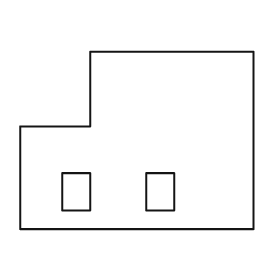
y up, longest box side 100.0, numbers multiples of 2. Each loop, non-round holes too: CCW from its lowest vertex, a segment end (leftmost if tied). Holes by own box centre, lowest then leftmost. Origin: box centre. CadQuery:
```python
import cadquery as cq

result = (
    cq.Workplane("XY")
    .moveTo(-50.0, -38.0)
    .lineTo(50.0, -38.0)
    .lineTo(50.0, 38.0)
    .lineTo(-20.0, 38.0)
    .lineTo(-20.0, 6.0)
    .lineTo(-50.0, 6.0)
    .close()
    .moveTo(-32.0, -30.0)
    .lineTo(-20.0, -30.0)
    .lineTo(-20.0, -14.0)
    .lineTo(-32.0, -14.0)
    .close()
    .moveTo(4.0, -30.0)
    .lineTo(16.0, -30.0)
    .lineTo(16.0, -14.0)
    .lineTo(4.0, -14.0)
    .close()
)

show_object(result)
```